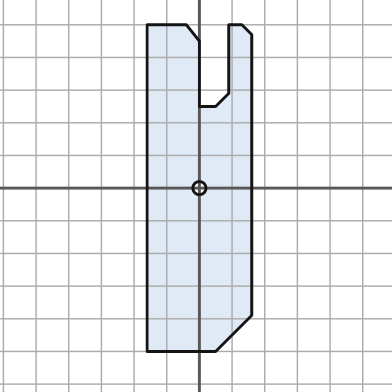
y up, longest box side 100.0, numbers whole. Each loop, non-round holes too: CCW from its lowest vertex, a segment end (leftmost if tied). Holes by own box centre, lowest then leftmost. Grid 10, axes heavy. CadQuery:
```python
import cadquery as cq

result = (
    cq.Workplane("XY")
    .moveTo(-16.0, -50.0)
    .lineTo(5.0, -50.0)
    .lineTo(16.0, -39.0)
    .lineTo(16.0, 47.0)
    .lineTo(13.0, 50.0)
    .lineTo(9.0, 50.0)
    .lineTo(9.0, 29.0)
    .lineTo(5.0, 25.0)
    .lineTo(0.0, 25.0)
    .lineTo(0.0, 45.0)
    .lineTo(-4.0, 50.0)
    .lineTo(-16.0, 50.0)
    .close()
    .moveTo(0.0, 0.0)
    .circle(2.0)
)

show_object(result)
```